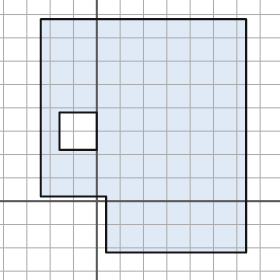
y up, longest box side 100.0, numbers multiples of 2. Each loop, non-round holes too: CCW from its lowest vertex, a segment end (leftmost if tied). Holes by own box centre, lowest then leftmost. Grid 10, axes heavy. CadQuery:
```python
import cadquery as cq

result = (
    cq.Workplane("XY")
    .moveTo(4.0, -22.0)
    .lineTo(64.0, -22.0)
    .lineTo(64.0, 78.0)
    .lineTo(-24.0, 78.0)
    .lineTo(-24.0, 2.0)
    .lineTo(4.0, 2.0)
    .close()
    .moveTo(-16.0, 22.0)
    .lineTo(0.0, 22.0)
    .lineTo(0.0, 38.0)
    .lineTo(-16.0, 38.0)
    .close()
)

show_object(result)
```